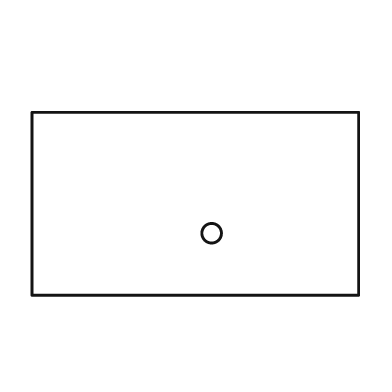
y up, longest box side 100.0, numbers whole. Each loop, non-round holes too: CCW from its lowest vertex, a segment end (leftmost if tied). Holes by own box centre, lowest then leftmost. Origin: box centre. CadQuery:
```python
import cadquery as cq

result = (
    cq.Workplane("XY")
    .moveTo(-50.0, -28.0)
    .lineTo(50.0, -28.0)
    .lineTo(50.0, 28.0)
    .lineTo(-50.0, 28.0)
    .close()
    .moveTo(5.0, -9.0)
    .circle(3.0)
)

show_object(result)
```